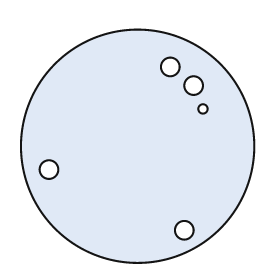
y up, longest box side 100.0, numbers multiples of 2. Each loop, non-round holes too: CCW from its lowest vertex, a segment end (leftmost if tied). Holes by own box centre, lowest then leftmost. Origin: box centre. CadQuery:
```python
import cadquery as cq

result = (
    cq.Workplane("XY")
    .moveTo(0.0, 0.0)
    .circle(50.0)
    .moveTo(20.0, -36.0)
    .circle(4.0)
    .moveTo(-38.0, -10.0)
    .circle(4.0)
    .moveTo(28.0, 16.0)
    .circle(2.0)
    .moveTo(24.0, 26.0)
    .circle(4.0)
    .moveTo(14.0, 34.0)
    .circle(4.0)
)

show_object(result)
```